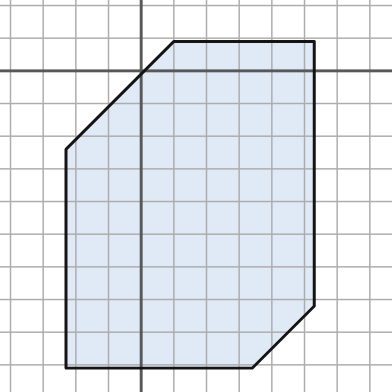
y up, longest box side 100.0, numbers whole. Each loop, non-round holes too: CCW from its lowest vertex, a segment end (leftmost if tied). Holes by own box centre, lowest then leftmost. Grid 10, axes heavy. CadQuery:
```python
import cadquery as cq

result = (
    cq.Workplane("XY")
    .moveTo(-23.0, -91.0)
    .lineTo(34.0, -91.0)
    .lineTo(53.0, -72.0)
    .lineTo(53.0, 9.0)
    .lineTo(10.0, 9.0)
    .lineTo(-23.0, -24.0)
    .close()
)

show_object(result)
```